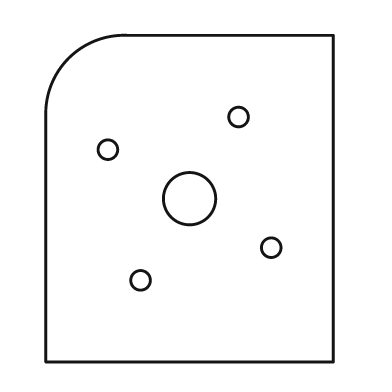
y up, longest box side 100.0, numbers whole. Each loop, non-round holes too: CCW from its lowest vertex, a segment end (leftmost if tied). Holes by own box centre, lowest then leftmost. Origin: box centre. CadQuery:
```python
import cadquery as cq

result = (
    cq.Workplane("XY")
    .moveTo(-44.0, -50.0)
    .lineTo(44.0, -50.0)
    .lineTo(44.0, 50.0)
    .lineTo(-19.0, 50.0)
    .threePointArc((-37.0, 43.0), (-44.0, 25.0))
    .close()
    .moveTo(-15.0, -25.0)
    .circle(3.0)
    .moveTo(25.0, -15.0)
    .circle(3.0)
    .moveTo(0.0, 0.0)
    .circle(8.0)
    .moveTo(-25.0, 15.0)
    .circle(3.0)
    .moveTo(15.0, 25.0)
    .circle(3.0)
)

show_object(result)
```